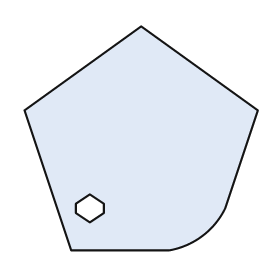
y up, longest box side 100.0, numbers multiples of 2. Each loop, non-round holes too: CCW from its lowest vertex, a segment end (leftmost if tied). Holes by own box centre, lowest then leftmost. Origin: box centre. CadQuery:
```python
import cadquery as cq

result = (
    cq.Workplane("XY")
    .moveTo(-30.0, -48.0)
    .lineTo(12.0, -48.0)
    .threePointArc((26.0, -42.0), (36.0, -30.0))
    .lineTo(50.0, 12.0)
    .lineTo(0.0, 48.0)
    .lineTo(-50.0, 12.0)
    .close()
    .moveTo(-22.0, -36.0)
    .lineTo(-16.0, -32.0)
    .lineTo(-16.0, -28.0)
    .lineTo(-22.0, -24.0)
    .lineTo(-28.0, -28.0)
    .lineTo(-28.0, -32.0)
    .close()
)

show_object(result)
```